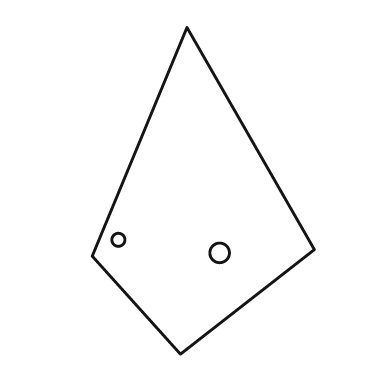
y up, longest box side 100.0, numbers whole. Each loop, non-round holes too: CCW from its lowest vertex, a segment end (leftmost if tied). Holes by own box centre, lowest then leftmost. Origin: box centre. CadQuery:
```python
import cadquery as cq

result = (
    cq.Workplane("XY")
    .moveTo(-7.0, -50.0)
    .lineTo(34.0, -18.0)
    .lineTo(-5.0, 50.0)
    .lineTo(-34.0, -20.0)
    .close()
    .moveTo(5.0, -19.0)
    .circle(3.0)
    .moveTo(-26.0, -15.0)
    .circle(2.0)
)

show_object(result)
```